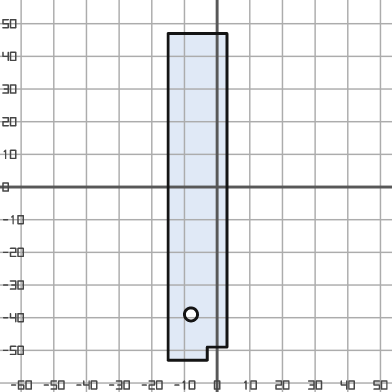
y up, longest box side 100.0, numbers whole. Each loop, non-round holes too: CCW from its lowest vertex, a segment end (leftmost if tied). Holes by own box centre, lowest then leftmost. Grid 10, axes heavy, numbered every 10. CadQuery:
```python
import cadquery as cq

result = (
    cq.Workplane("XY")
    .moveTo(-15.0, -53.0)
    .lineTo(-3.0, -53.0)
    .lineTo(-3.0, -49.0)
    .lineTo(3.0, -49.0)
    .lineTo(3.0, 47.0)
    .lineTo(-15.0, 47.0)
    .close()
    .moveTo(-8.0, -39.0)
    .circle(2.0)
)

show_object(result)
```